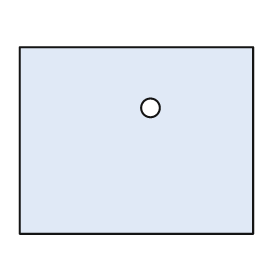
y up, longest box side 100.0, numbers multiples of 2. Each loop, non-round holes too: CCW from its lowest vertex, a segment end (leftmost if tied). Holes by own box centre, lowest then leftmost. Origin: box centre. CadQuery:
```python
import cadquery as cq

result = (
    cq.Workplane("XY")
    .moveTo(-50.0, -40.0)
    .lineTo(50.0, -40.0)
    .lineTo(50.0, 40.0)
    .lineTo(-50.0, 40.0)
    .close()
    .moveTo(6.0, 14.0)
    .circle(4.0)
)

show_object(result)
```